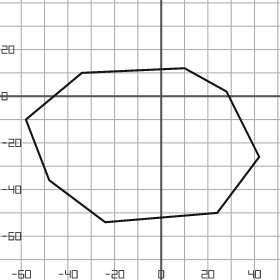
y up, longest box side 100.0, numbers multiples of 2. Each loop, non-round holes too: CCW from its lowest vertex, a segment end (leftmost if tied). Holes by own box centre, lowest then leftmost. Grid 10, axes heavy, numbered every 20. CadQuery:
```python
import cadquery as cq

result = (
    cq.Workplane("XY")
    .moveTo(-24.0, -54.0)
    .lineTo(24.0, -50.0)
    .lineTo(42.0, -26.0)
    .lineTo(28.0, 2.0)
    .lineTo(10.0, 12.0)
    .lineTo(-34.0, 10.0)
    .lineTo(-58.0, -10.0)
    .lineTo(-48.0, -36.0)
    .close()
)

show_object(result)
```